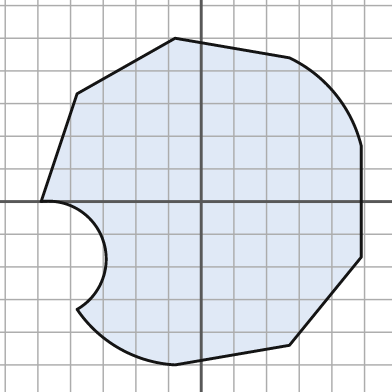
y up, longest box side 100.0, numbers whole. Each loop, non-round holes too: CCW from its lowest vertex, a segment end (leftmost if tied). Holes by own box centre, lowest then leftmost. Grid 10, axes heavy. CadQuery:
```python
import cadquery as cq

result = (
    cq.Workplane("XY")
    .moveTo(-8.0, -50.0)
    .lineTo(27.0, -44.0)
    .lineTo(49.0, -17.0)
    .lineTo(49.0, 17.0)
    .threePointArc((41.0, 33.0), (27.0, 44.0))
    .lineTo(-8.0, 50.0)
    .lineTo(-38.0, 33.0)
    .lineTo(-49.0, 0.0)
    .threePointArc((-30.0, -12.0), (-38.0, -33.0))
    .threePointArc((-25.0, -45.0), (-8.0, -50.0))
    .close()
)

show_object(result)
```